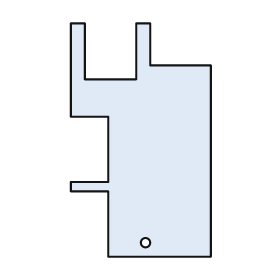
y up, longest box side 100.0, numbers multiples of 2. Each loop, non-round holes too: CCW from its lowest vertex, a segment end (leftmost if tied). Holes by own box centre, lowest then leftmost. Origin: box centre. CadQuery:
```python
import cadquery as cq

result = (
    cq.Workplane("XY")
    .moveTo(-14.0, -50.0)
    .lineTo(30.0, -50.0)
    .lineTo(30.0, 32.0)
    .lineTo(4.0, 32.0)
    .lineTo(4.0, 50.0)
    .lineTo(-2.0, 50.0)
    .lineTo(-2.0, 26.0)
    .lineTo(-24.0, 26.0)
    .lineTo(-24.0, 50.0)
    .lineTo(-30.0, 50.0)
    .lineTo(-30.0, 10.0)
    .lineTo(-14.0, 10.0)
    .lineTo(-14.0, -18.0)
    .lineTo(-30.0, -18.0)
    .lineTo(-30.0, -22.0)
    .lineTo(-14.0, -22.0)
    .close()
    .moveTo(2.0, -44.0)
    .circle(2.0)
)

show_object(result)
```